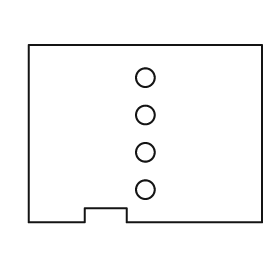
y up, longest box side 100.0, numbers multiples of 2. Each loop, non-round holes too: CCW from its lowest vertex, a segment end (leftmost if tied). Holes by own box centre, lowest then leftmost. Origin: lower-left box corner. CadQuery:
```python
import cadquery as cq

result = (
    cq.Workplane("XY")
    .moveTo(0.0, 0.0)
    .lineTo(24.0, 0.0)
    .lineTo(24.0, 6.0)
    .lineTo(42.0, 6.0)
    .lineTo(42.0, 0.0)
    .lineTo(100.0, 0.0)
    .lineTo(100.0, 76.0)
    .lineTo(0.0, 76.0)
    .close()
    .moveTo(50.0, 14.0)
    .circle(4.0)
    .moveTo(50.0, 30.0)
    .circle(4.0)
    .moveTo(50.0, 46.0)
    .circle(4.0)
    .moveTo(50.0, 62.0)
    .circle(4.0)
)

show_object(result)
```